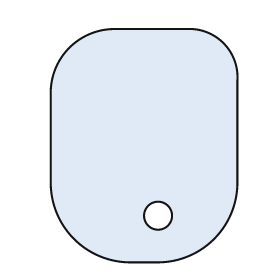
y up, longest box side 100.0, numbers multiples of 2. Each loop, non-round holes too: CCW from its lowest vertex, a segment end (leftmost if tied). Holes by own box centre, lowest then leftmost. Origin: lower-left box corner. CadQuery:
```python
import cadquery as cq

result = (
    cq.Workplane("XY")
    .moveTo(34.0, 0.0)
    .lineTo(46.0, 0.0)
    .threePointArc((70.0, 10.0), (80.0, 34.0))
    .lineTo(80.0, 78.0)
    .threePointArc((74.0, 94.0), (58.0, 100.0))
    .lineTo(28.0, 100.0)
    .threePointArc((8.0, 92.0), (0.0, 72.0))
    .lineTo(0.0, 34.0)
    .threePointArc((10.0, 10.0), (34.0, 0.0))
    .close()
    .moveTo(46.0, 20.0)
    .circle(6.0)
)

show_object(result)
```